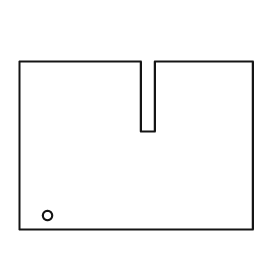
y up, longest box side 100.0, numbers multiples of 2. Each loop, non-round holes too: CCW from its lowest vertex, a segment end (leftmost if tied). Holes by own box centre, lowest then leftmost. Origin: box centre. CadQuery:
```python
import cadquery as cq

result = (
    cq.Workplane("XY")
    .moveTo(-50.0, -36.0)
    .lineTo(50.0, -36.0)
    .lineTo(50.0, 36.0)
    .lineTo(8.0, 36.0)
    .lineTo(8.0, 6.0)
    .lineTo(2.0, 6.0)
    .lineTo(2.0, 36.0)
    .lineTo(-50.0, 36.0)
    .close()
    .moveTo(-38.0, -30.0)
    .circle(2.0)
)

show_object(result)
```